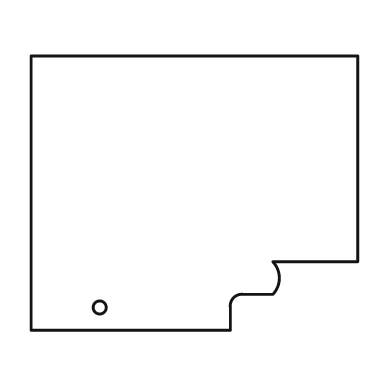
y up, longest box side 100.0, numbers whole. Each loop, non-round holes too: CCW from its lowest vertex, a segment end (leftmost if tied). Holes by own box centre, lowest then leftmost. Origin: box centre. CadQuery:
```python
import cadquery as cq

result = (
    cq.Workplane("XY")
    .moveTo(-50.0, -42.0)
    .lineTo(11.0, -42.0)
    .lineTo(11.0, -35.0)
    .threePointArc((12.0, -32.0), (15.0, -31.0))
    .lineTo(24.0, -31.0)
    .threePointArc((26.0, -26.0), (24.0, -21.0))
    .lineTo(50.0, -21.0)
    .lineTo(50.0, 42.0)
    .lineTo(-50.0, 42.0)
    .close()
    .moveTo(-29.0, -35.0)
    .circle(2.0)
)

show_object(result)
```